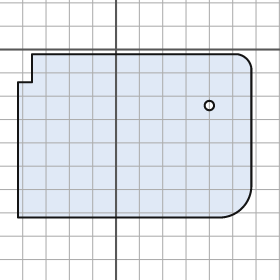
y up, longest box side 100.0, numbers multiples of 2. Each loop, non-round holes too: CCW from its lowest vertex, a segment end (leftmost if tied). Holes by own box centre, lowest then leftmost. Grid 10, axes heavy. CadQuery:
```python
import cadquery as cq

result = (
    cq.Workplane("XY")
    .moveTo(-42.0, -72.0)
    .lineTo(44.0, -72.0)
    .threePointArc((54.0, -68.0), (58.0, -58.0))
    .lineTo(58.0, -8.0)
    .threePointArc((56.0, -4.0), (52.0, -2.0))
    .lineTo(-36.0, -2.0)
    .lineTo(-36.0, -14.0)
    .lineTo(-42.0, -14.0)
    .close()
    .moveTo(40.0, -24.0)
    .circle(2.0)
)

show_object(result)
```